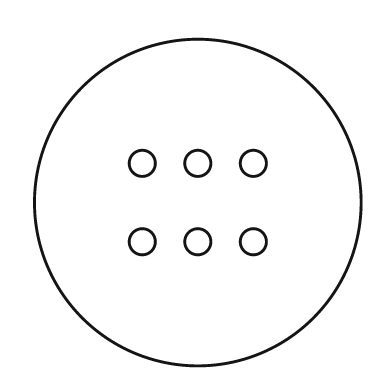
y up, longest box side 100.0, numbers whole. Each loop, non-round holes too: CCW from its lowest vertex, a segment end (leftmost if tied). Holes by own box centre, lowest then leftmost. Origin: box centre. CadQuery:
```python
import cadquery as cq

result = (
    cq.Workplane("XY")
    .moveTo(0.0, 0.0)
    .circle(50.0)
    .moveTo(-17.0, -12.0)
    .circle(4.0)
    .moveTo(0.0, -12.0)
    .circle(4.0)
    .moveTo(17.0, -12.0)
    .circle(4.0)
    .moveTo(-17.0, 12.0)
    .circle(4.0)
    .moveTo(0.0, 12.0)
    .circle(4.0)
    .moveTo(17.0, 12.0)
    .circle(4.0)
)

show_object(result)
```